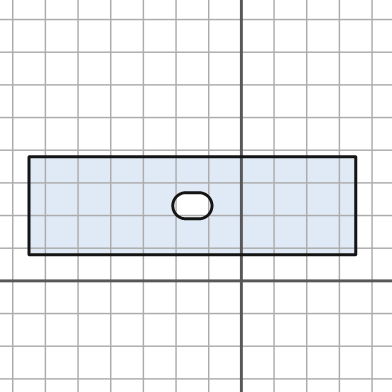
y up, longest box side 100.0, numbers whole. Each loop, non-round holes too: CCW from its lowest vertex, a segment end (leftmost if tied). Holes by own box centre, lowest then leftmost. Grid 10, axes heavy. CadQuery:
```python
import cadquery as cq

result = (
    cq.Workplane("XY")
    .moveTo(-65.0, 8.0)
    .lineTo(35.0, 8.0)
    .lineTo(35.0, 38.0)
    .lineTo(-65.0, 38.0)
    .close()
    .moveTo(-17.0, 19.0)
    .lineTo(-13.0, 19.0)
    .threePointArc((-9.0, 23.0), (-13.0, 27.0))
    .lineTo(-17.0, 27.0)
    .threePointArc((-21.0, 23.0), (-17.0, 19.0))
    .close()
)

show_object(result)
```